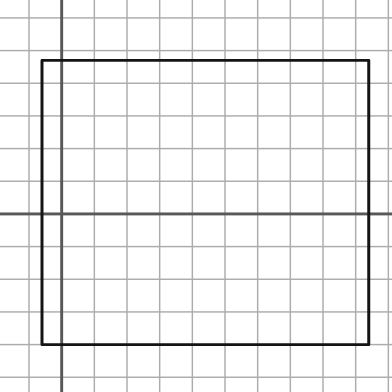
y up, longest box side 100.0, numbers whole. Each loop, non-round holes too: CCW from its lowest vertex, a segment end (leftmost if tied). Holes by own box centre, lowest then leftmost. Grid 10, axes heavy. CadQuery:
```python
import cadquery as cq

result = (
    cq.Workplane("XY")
    .moveTo(-6.0, -40.0)
    .lineTo(94.0, -40.0)
    .lineTo(94.0, 47.0)
    .lineTo(-6.0, 47.0)
    .close()
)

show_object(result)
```